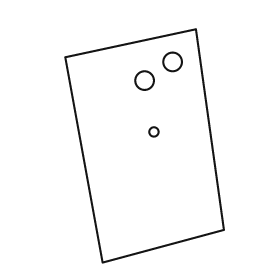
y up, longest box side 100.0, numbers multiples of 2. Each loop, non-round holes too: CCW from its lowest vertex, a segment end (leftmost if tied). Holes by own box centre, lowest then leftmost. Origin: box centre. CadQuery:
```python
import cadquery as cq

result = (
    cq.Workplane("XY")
    .moveTo(-18.0, -50.0)
    .lineTo(34.0, -36.0)
    .lineTo(22.0, 50.0)
    .lineTo(-34.0, 38.0)
    .close()
    .moveTo(4.0, 6.0)
    .circle(2.0)
    .moveTo(0.0, 28.0)
    .circle(4.0)
    .moveTo(12.0, 36.0)
    .circle(4.0)
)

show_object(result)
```